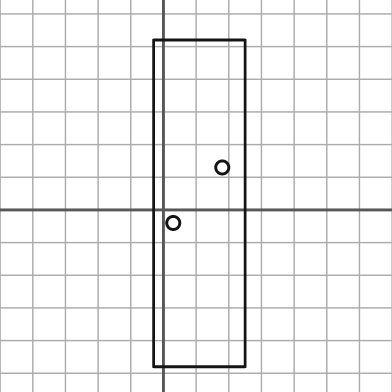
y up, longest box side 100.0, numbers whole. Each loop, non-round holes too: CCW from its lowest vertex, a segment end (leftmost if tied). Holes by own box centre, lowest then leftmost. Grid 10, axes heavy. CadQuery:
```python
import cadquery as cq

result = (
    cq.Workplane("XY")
    .moveTo(-3.0, -48.0)
    .lineTo(25.0, -48.0)
    .lineTo(25.0, 52.0)
    .lineTo(-3.0, 52.0)
    .close()
    .moveTo(3.0, -4.0)
    .circle(2.0)
    .moveTo(18.0, 13.0)
    .circle(2.0)
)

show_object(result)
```